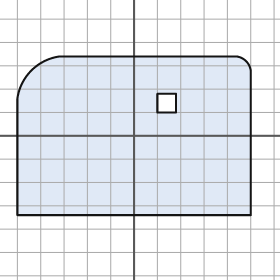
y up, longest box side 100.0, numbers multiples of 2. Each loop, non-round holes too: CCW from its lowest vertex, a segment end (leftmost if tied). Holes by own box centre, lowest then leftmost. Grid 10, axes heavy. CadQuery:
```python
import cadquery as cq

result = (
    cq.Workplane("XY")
    .moveTo(-50.0, -34.0)
    .lineTo(50.0, -34.0)
    .lineTo(50.0, 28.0)
    .threePointArc((48.0, 32.0), (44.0, 34.0))
    .lineTo(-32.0, 34.0)
    .threePointArc((-44.0, 28.0), (-50.0, 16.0))
    .close()
    .moveTo(10.0, 10.0)
    .lineTo(18.0, 10.0)
    .lineTo(18.0, 18.0)
    .lineTo(10.0, 18.0)
    .close()
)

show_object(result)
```